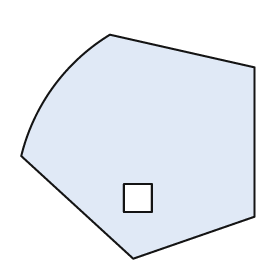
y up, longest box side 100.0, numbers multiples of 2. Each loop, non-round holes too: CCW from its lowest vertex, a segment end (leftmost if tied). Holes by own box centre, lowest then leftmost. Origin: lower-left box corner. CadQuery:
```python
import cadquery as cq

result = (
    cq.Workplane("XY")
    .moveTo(48.0, 0.0)
    .lineTo(100.0, 18.0)
    .lineTo(100.0, 82.0)
    .lineTo(38.0, 96.0)
    .threePointArc((14.0, 74.0), (0.0, 44.0))
    .close()
    .moveTo(44.0, 20.0)
    .lineTo(56.0, 20.0)
    .lineTo(56.0, 32.0)
    .lineTo(44.0, 32.0)
    .close()
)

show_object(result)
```